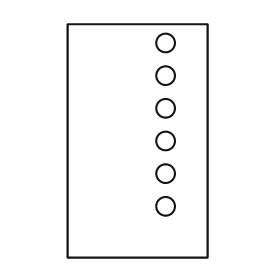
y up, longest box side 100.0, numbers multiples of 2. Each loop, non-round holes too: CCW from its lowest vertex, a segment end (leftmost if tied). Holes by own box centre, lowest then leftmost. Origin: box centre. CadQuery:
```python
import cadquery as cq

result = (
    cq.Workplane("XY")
    .moveTo(-30.0, -50.0)
    .lineTo(30.0, -50.0)
    .lineTo(30.0, 50.0)
    .lineTo(-30.0, 50.0)
    .close()
    .moveTo(12.0, -28.0)
    .circle(4.0)
    .moveTo(12.0, -14.0)
    .circle(4.0)
    .moveTo(12.0, 0.0)
    .circle(4.0)
    .moveTo(12.0, 14.0)
    .circle(4.0)
    .moveTo(12.0, 28.0)
    .circle(4.0)
    .moveTo(12.0, 42.0)
    .circle(4.0)
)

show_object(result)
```